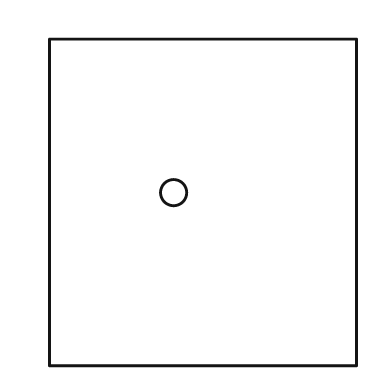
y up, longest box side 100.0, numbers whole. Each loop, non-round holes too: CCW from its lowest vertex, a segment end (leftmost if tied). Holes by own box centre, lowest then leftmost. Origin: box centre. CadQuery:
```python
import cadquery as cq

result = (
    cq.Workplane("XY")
    .moveTo(-47.0, -50.0)
    .lineTo(47.0, -50.0)
    .lineTo(47.0, 50.0)
    .lineTo(-47.0, 50.0)
    .close()
    .moveTo(-9.0, 3.0)
    .circle(4.0)
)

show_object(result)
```